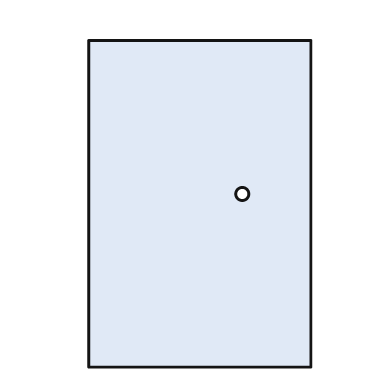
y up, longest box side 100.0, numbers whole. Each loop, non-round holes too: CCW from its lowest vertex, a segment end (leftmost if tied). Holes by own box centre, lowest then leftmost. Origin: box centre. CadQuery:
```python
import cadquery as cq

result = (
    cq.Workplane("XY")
    .moveTo(-34.0, -50.0)
    .lineTo(34.0, -50.0)
    .lineTo(34.0, 50.0)
    .lineTo(-34.0, 50.0)
    .close()
    .moveTo(13.0, 3.0)
    .circle(2.0)
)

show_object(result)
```